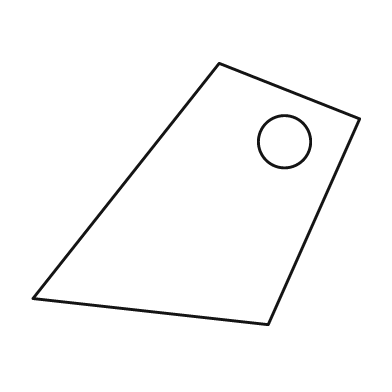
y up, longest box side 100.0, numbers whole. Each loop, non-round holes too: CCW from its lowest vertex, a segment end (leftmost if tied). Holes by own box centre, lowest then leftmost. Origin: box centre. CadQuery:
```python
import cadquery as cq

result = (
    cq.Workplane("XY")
    .moveTo(22.0, -40.0)
    .lineTo(50.0, 23.0)
    .lineTo(7.0, 40.0)
    .lineTo(-50.0, -32.0)
    .close()
    .moveTo(27.0, 16.0)
    .circle(8.0)
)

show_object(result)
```